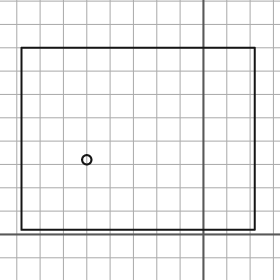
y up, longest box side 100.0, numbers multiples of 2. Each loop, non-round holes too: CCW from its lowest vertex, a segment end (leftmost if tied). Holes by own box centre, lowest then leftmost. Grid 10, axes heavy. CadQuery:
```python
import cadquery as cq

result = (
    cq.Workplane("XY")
    .moveTo(-78.0, 2.0)
    .lineTo(22.0, 2.0)
    .lineTo(22.0, 80.0)
    .lineTo(-78.0, 80.0)
    .close()
    .moveTo(-50.0, 32.0)
    .circle(2.0)
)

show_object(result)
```